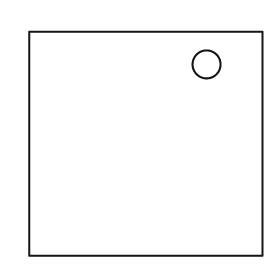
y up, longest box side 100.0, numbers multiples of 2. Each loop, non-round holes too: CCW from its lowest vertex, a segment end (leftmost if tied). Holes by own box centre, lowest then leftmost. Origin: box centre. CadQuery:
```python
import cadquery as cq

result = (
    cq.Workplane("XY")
    .moveTo(-50.0, -48.0)
    .lineTo(50.0, -48.0)
    .lineTo(50.0, 48.0)
    .lineTo(-50.0, 48.0)
    .close()
    .moveTo(26.0, 34.0)
    .circle(6.0)
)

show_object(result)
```